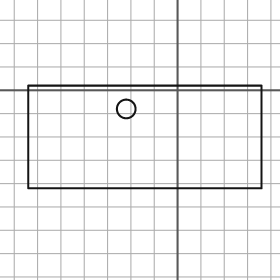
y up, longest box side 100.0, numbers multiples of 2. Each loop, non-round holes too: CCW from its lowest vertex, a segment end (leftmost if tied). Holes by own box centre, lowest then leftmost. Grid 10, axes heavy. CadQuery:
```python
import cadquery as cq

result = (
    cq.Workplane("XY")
    .moveTo(-64.0, -42.0)
    .lineTo(36.0, -42.0)
    .lineTo(36.0, 2.0)
    .lineTo(-64.0, 2.0)
    .close()
    .moveTo(-22.0, -8.0)
    .circle(4.0)
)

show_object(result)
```